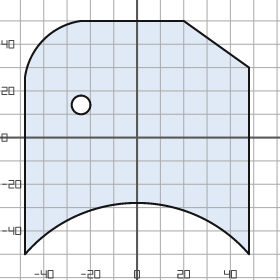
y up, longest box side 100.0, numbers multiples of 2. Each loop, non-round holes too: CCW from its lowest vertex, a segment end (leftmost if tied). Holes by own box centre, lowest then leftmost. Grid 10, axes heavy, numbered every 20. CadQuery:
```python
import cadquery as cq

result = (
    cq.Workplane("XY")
    .moveTo(-48.0, -50.0)
    .threePointArc((0.0, -28.0), (48.0, -50.0))
    .lineTo(48.0, 30.0)
    .lineTo(20.0, 50.0)
    .lineTo(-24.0, 50.0)
    .threePointArc((-40.0, 42.0), (-48.0, 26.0))
    .close()
    .moveTo(-24.0, 14.0)
    .circle(4.0)
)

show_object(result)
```